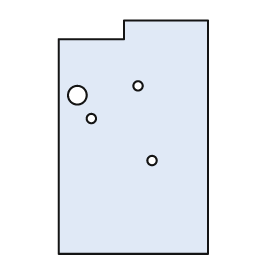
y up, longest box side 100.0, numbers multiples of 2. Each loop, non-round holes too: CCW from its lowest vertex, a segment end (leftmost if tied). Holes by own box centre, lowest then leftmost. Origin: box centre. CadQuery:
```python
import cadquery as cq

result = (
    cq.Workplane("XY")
    .moveTo(-32.0, -50.0)
    .lineTo(32.0, -50.0)
    .lineTo(32.0, 50.0)
    .lineTo(-4.0, 50.0)
    .lineTo(-4.0, 42.0)
    .lineTo(-32.0, 42.0)
    .close()
    .moveTo(8.0, -10.0)
    .circle(2.0)
    .moveTo(-18.0, 8.0)
    .circle(2.0)
    .moveTo(-24.0, 18.0)
    .circle(4.0)
    .moveTo(2.0, 22.0)
    .circle(2.0)
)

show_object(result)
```